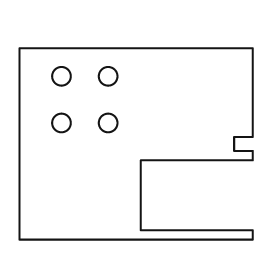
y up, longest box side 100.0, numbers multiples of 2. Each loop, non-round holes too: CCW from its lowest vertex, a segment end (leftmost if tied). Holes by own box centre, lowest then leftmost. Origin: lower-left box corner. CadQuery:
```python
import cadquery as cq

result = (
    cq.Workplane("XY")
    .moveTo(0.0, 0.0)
    .lineTo(100.0, 0.0)
    .lineTo(100.0, 4.0)
    .lineTo(52.0, 4.0)
    .lineTo(52.0, 34.0)
    .lineTo(100.0, 34.0)
    .lineTo(100.0, 38.0)
    .lineTo(92.0, 38.0)
    .lineTo(92.0, 44.0)
    .lineTo(100.0, 44.0)
    .lineTo(100.0, 82.0)
    .lineTo(0.0, 82.0)
    .close()
    .moveTo(18.0, 50.0)
    .circle(4.0)
    .moveTo(38.0, 50.0)
    .circle(4.0)
    .moveTo(18.0, 70.0)
    .circle(4.0)
    .moveTo(38.0, 70.0)
    .circle(4.0)
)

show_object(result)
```